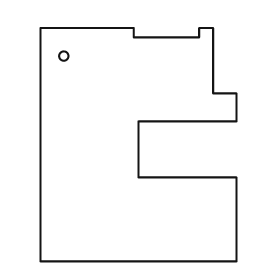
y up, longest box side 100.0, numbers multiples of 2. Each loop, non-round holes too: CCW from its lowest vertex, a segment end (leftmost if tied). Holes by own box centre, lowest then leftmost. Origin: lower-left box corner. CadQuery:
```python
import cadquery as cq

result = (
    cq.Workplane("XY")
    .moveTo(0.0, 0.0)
    .lineTo(84.0, 0.0)
    .lineTo(84.0, 36.0)
    .lineTo(42.0, 36.0)
    .lineTo(42.0, 60.0)
    .lineTo(84.0, 60.0)
    .lineTo(84.0, 72.0)
    .lineTo(74.0, 72.0)
    .lineTo(74.0, 100.0)
    .lineTo(68.0, 100.0)
    .lineTo(68.0, 96.0)
    .lineTo(40.0, 96.0)
    .lineTo(40.0, 100.0)
    .lineTo(0.0, 100.0)
    .close()
    .moveTo(10.0, 88.0)
    .circle(2.0)
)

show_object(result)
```